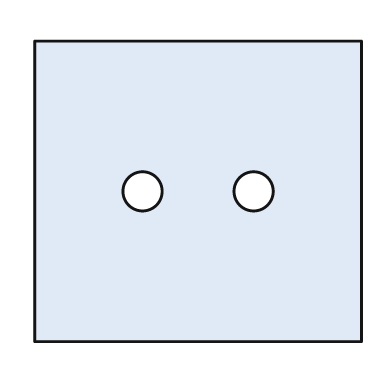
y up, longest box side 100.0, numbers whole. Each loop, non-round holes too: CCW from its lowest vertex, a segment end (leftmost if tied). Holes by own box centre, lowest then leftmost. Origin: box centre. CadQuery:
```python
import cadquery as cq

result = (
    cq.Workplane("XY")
    .moveTo(-50.0, -46.0)
    .lineTo(50.0, -46.0)
    .lineTo(50.0, 46.0)
    .lineTo(-50.0, 46.0)
    .close()
    .moveTo(-17.0, 0.0)
    .circle(6.0)
    .moveTo(17.0, 0.0)
    .circle(6.0)
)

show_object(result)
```